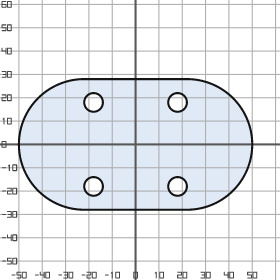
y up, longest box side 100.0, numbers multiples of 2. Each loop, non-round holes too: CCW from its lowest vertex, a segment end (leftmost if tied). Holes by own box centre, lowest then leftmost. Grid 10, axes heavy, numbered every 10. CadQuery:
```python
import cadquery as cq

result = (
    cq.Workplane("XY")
    .moveTo(-22.0, -28.0)
    .lineTo(22.0, -28.0)
    .threePointArc((50.0, 0.0), (22.0, 28.0))
    .lineTo(-22.0, 28.0)
    .threePointArc((-50.0, 0.0), (-22.0, -28.0))
    .close()
    .moveTo(-18.0, -18.0)
    .circle(4.0)
    .moveTo(18.0, -18.0)
    .circle(4.0)
    .moveTo(-18.0, 18.0)
    .circle(4.0)
    .moveTo(18.0, 18.0)
    .circle(4.0)
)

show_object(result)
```